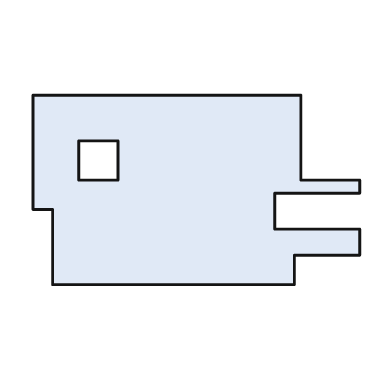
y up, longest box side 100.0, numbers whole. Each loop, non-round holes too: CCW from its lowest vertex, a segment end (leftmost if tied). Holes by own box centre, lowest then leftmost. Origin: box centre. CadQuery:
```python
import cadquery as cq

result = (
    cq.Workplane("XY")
    .moveTo(-44.0, -29.0)
    .lineTo(30.0, -29.0)
    .lineTo(30.0, -20.0)
    .lineTo(50.0, -20.0)
    .lineTo(50.0, -12.0)
    .lineTo(24.0, -12.0)
    .lineTo(24.0, -1.0)
    .lineTo(50.0, -1.0)
    .lineTo(50.0, 3.0)
    .lineTo(32.0, 3.0)
    .lineTo(32.0, 29.0)
    .lineTo(-50.0, 29.0)
    .lineTo(-50.0, -6.0)
    .lineTo(-44.0, -6.0)
    .close()
    .moveTo(-36.0, 3.0)
    .lineTo(-24.0, 3.0)
    .lineTo(-24.0, 15.0)
    .lineTo(-36.0, 15.0)
    .close()
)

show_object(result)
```